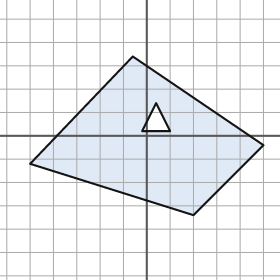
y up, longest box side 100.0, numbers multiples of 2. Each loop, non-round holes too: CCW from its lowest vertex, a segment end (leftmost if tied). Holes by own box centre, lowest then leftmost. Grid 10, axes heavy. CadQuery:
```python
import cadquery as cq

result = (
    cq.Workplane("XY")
    .moveTo(20.0, -34.0)
    .lineTo(50.0, -4.0)
    .lineTo(-6.0, 34.0)
    .lineTo(-50.0, -12.0)
    .close()
    .moveTo(-2.0, 2.0)
    .lineTo(10.0, 2.0)
    .lineTo(4.0, 14.0)
    .close()
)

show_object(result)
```